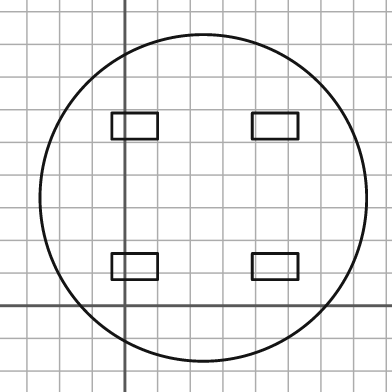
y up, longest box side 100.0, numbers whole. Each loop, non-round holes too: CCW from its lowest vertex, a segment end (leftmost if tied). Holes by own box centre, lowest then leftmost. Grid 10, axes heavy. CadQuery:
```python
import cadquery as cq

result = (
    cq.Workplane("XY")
    .moveTo(24.0, 33.0)
    .circle(50.0)
    .moveTo(-4.0, 8.0)
    .lineTo(10.0, 8.0)
    .lineTo(10.0, 16.0)
    .lineTo(-4.0, 16.0)
    .close()
    .moveTo(39.0, 8.0)
    .lineTo(53.0, 8.0)
    .lineTo(53.0, 16.0)
    .lineTo(39.0, 16.0)
    .close()
    .moveTo(-4.0, 51.0)
    .lineTo(10.0, 51.0)
    .lineTo(10.0, 59.0)
    .lineTo(-4.0, 59.0)
    .close()
    .moveTo(39.0, 51.0)
    .lineTo(53.0, 51.0)
    .lineTo(53.0, 59.0)
    .lineTo(39.0, 59.0)
    .close()
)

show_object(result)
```